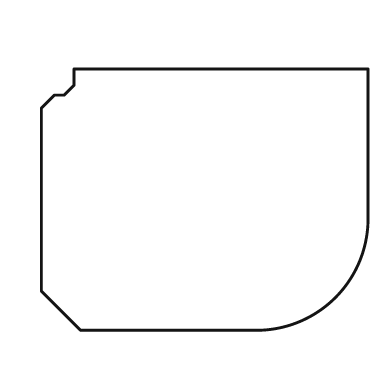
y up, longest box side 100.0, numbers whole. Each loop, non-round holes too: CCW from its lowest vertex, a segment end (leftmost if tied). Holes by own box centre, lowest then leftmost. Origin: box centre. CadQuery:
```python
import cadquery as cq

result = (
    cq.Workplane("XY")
    .moveTo(-38.0, -40.0)
    .lineTo(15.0, -40.0)
    .threePointArc((40.0, -30.0), (50.0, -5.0))
    .lineTo(50.0, 40.0)
    .lineTo(-40.0, 40.0)
    .lineTo(-40.0, 35.0)
    .lineTo(-43.0, 32.0)
    .lineTo(-46.0, 32.0)
    .lineTo(-50.0, 28.0)
    .lineTo(-50.0, -28.0)
    .close()
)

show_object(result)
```